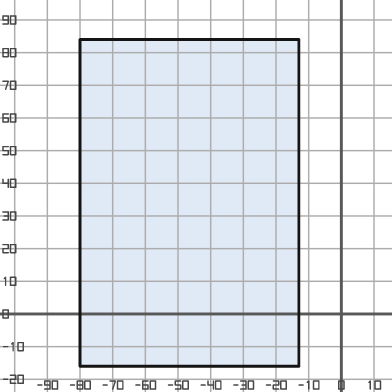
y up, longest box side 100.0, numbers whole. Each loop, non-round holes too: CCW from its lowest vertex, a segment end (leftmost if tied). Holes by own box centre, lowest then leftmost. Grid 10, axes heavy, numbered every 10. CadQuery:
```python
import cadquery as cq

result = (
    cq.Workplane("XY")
    .moveTo(-80.0, -16.0)
    .lineTo(-13.0, -16.0)
    .lineTo(-13.0, 84.0)
    .lineTo(-80.0, 84.0)
    .close()
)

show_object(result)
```